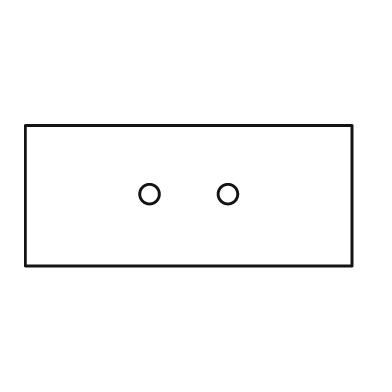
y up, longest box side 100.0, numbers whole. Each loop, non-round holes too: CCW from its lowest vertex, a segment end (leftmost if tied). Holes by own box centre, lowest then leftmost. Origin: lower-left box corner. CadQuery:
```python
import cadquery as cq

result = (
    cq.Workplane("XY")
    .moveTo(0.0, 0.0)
    .lineTo(100.0, 0.0)
    .lineTo(100.0, 43.0)
    .lineTo(0.0, 43.0)
    .close()
    .moveTo(38.0, 22.0)
    .circle(3.0)
    .moveTo(62.0, 22.0)
    .circle(3.0)
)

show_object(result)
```